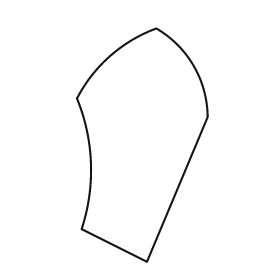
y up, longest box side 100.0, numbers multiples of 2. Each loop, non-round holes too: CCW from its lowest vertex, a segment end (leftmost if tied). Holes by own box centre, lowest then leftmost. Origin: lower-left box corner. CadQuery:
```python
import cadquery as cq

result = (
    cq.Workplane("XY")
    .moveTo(30.0, 0.0)
    .lineTo(56.0, 62.0)
    .threePointArc((50.0, 84.0), (34.0, 100.0))
    .threePointArc((14.0, 88.0), (0.0, 70.0))
    .threePointArc((6.0, 42.0), (2.0, 14.0))
    .close()
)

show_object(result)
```